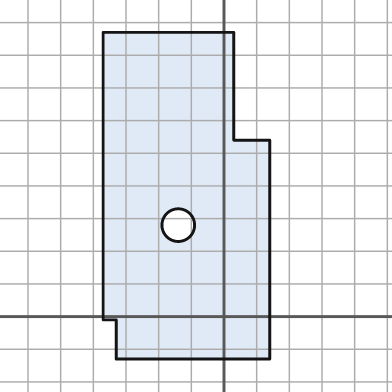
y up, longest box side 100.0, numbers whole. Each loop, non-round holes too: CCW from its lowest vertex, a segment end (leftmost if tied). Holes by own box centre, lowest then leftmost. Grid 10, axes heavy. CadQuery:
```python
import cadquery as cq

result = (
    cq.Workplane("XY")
    .moveTo(-33.0, -13.0)
    .lineTo(14.0, -13.0)
    .lineTo(14.0, 54.0)
    .lineTo(3.0, 54.0)
    .lineTo(3.0, 87.0)
    .lineTo(-37.0, 87.0)
    .lineTo(-37.0, -1.0)
    .lineTo(-33.0, -1.0)
    .close()
    .moveTo(-14.0, 28.0)
    .circle(5.0)
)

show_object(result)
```